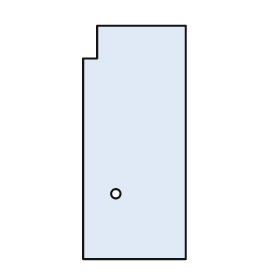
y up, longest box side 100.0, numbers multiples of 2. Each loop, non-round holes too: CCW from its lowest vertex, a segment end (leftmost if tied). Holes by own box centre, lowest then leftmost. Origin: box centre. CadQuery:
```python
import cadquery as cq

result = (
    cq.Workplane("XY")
    .moveTo(-22.0, -50.0)
    .lineTo(22.0, -50.0)
    .lineTo(22.0, 50.0)
    .lineTo(-16.0, 50.0)
    .lineTo(-16.0, 36.0)
    .lineTo(-22.0, 36.0)
    .close()
    .moveTo(-8.0, -22.0)
    .circle(2.0)
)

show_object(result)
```